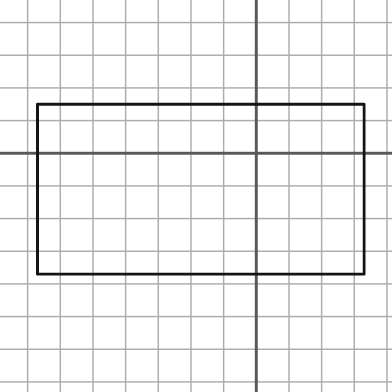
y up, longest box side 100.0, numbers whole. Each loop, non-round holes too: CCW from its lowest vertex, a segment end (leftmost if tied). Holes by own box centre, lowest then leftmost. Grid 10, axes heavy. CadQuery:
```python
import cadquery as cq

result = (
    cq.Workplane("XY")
    .moveTo(-67.0, -37.0)
    .lineTo(33.0, -37.0)
    .lineTo(33.0, 15.0)
    .lineTo(-67.0, 15.0)
    .close()
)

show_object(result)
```